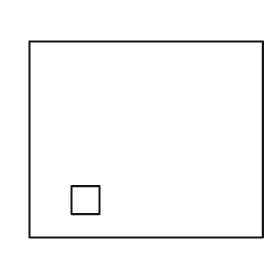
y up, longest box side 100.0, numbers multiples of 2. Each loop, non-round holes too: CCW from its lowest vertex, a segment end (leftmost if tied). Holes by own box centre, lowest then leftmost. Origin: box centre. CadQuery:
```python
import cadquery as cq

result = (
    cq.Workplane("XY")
    .moveTo(-50.0, -42.0)
    .lineTo(50.0, -42.0)
    .lineTo(50.0, 42.0)
    .lineTo(-50.0, 42.0)
    .close()
    .moveTo(-32.0, -32.0)
    .lineTo(-20.0, -32.0)
    .lineTo(-20.0, -20.0)
    .lineTo(-32.0, -20.0)
    .close()
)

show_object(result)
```